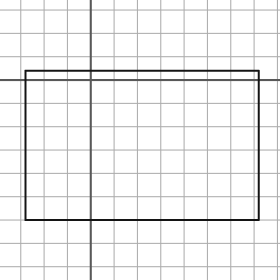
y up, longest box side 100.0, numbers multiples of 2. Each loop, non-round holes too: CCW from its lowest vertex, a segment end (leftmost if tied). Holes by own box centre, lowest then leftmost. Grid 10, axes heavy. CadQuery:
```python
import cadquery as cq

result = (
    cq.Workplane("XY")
    .moveTo(-28.0, -60.0)
    .lineTo(72.0, -60.0)
    .lineTo(72.0, 4.0)
    .lineTo(-28.0, 4.0)
    .close()
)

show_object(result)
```